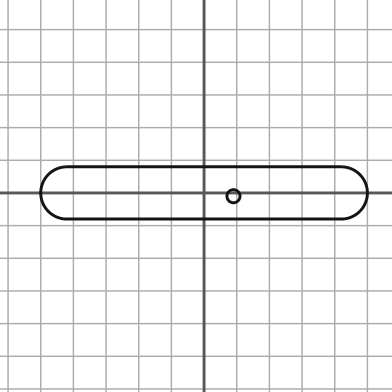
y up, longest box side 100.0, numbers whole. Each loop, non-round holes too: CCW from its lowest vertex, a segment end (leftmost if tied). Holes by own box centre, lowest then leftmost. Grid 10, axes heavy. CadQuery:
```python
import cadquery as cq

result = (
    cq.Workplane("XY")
    .moveTo(-42.0, -8.0)
    .lineTo(42.0, -8.0)
    .threePointArc((50.0, 0.0), (42.0, 8.0))
    .lineTo(-42.0, 8.0)
    .threePointArc((-50.0, 0.0), (-42.0, -8.0))
    .close()
    .moveTo(9.0, -1.0)
    .circle(2.0)
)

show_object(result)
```